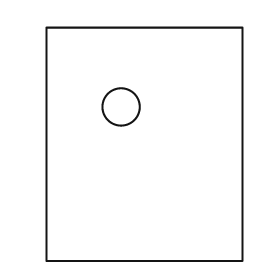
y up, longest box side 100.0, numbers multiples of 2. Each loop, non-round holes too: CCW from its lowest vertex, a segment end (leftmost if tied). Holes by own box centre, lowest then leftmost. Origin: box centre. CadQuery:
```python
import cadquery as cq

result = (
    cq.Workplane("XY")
    .moveTo(-42.0, -50.0)
    .lineTo(42.0, -50.0)
    .lineTo(42.0, 50.0)
    .lineTo(-42.0, 50.0)
    .close()
    .moveTo(-10.0, 16.0)
    .circle(8.0)
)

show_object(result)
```